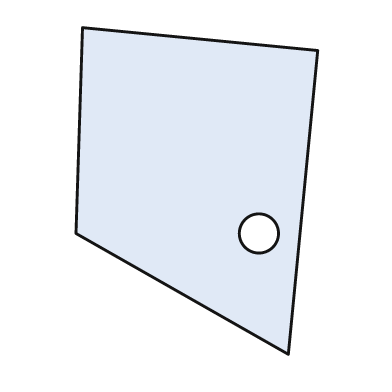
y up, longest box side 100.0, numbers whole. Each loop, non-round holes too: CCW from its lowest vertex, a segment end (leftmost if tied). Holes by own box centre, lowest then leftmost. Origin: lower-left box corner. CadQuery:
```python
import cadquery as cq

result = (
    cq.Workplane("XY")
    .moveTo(65.0, 0.0)
    .lineTo(74.0, 93.0)
    .lineTo(2.0, 100.0)
    .lineTo(0.0, 37.0)
    .close()
    .moveTo(56.0, 37.0)
    .circle(6.0)
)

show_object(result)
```